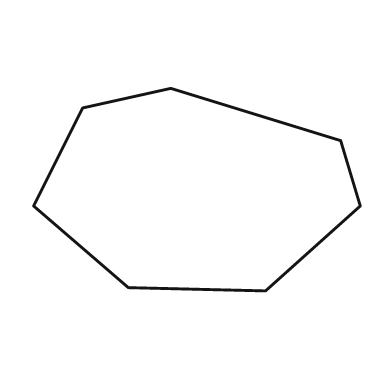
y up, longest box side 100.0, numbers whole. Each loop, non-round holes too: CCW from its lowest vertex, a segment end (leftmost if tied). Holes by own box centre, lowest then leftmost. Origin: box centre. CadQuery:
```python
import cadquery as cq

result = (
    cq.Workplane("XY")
    .moveTo(21.0, -31.0)
    .lineTo(50.0, -5.0)
    .lineTo(44.0, 15.0)
    .lineTo(-8.0, 31.0)
    .lineTo(-35.0, 25.0)
    .lineTo(-50.0, -5.0)
    .lineTo(-21.0, -30.0)
    .close()
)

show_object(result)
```